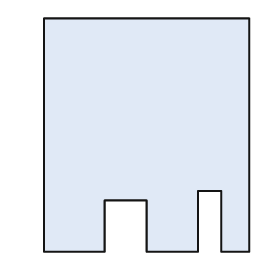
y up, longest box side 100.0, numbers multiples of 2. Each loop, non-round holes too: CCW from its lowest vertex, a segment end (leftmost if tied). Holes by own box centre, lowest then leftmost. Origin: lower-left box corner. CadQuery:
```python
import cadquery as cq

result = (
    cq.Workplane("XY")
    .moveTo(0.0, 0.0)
    .lineTo(26.0, 0.0)
    .lineTo(26.0, 22.0)
    .lineTo(44.0, 22.0)
    .lineTo(44.0, 0.0)
    .lineTo(66.0, 0.0)
    .lineTo(66.0, 26.0)
    .lineTo(76.0, 26.0)
    .lineTo(76.0, 0.0)
    .lineTo(88.0, 0.0)
    .lineTo(88.0, 100.0)
    .lineTo(0.0, 100.0)
    .close()
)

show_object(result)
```